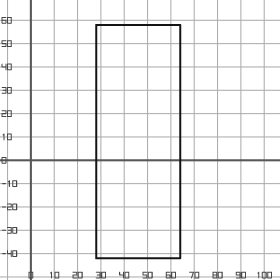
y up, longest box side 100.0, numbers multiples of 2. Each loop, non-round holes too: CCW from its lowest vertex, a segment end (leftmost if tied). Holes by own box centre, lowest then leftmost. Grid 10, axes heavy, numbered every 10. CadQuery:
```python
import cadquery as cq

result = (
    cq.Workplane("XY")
    .moveTo(28.0, -42.0)
    .lineTo(64.0, -42.0)
    .lineTo(64.0, 58.0)
    .lineTo(28.0, 58.0)
    .close()
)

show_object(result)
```